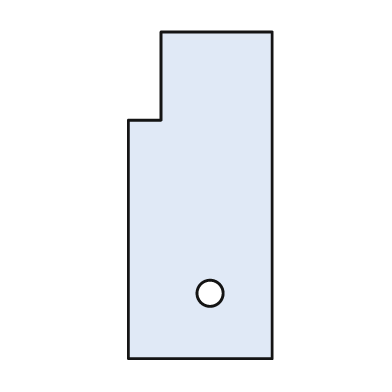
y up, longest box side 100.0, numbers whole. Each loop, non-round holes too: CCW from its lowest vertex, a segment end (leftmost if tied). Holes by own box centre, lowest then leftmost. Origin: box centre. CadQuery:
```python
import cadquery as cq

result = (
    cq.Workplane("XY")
    .moveTo(-22.0, -50.0)
    .lineTo(22.0, -50.0)
    .lineTo(22.0, 50.0)
    .lineTo(-12.0, 50.0)
    .lineTo(-12.0, 23.0)
    .lineTo(-22.0, 23.0)
    .close()
    .moveTo(3.0, -30.0)
    .circle(4.0)
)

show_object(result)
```